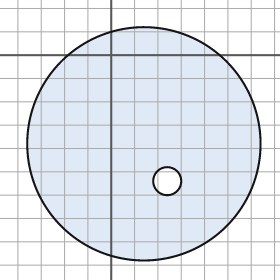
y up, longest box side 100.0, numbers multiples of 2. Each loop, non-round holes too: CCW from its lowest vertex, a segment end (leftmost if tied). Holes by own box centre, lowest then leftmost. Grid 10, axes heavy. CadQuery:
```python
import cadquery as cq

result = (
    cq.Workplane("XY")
    .moveTo(14.0, -38.0)
    .circle(50.0)
    .moveTo(24.0, -54.0)
    .circle(6.0)
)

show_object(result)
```